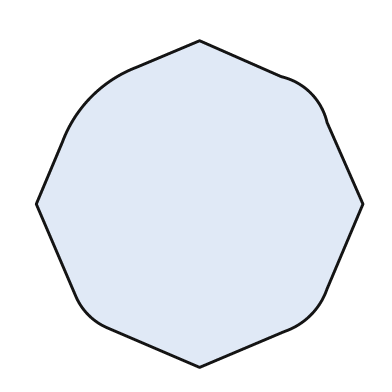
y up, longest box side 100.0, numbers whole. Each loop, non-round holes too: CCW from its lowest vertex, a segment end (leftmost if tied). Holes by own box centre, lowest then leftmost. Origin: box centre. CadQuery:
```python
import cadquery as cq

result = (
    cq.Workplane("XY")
    .moveTo(0.0, -50.0)
    .lineTo(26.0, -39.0)
    .threePointArc((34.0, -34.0), (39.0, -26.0))
    .lineTo(50.0, 0.0)
    .lineTo(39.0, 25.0)
    .threePointArc((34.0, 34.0), (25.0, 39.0))
    .lineTo(0.0, 50.0)
    .lineTo(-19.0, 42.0)
    .threePointArc((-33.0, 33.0), (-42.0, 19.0))
    .lineTo(-50.0, 0.0)
    .lineTo(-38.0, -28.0)
    .threePointArc((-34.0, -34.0), (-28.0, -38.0))
    .close()
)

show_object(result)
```